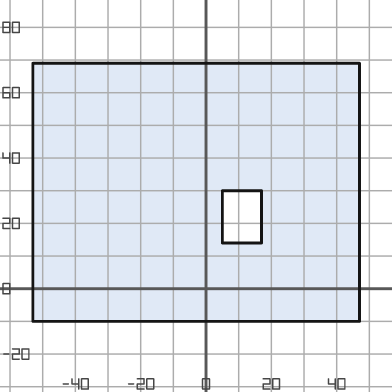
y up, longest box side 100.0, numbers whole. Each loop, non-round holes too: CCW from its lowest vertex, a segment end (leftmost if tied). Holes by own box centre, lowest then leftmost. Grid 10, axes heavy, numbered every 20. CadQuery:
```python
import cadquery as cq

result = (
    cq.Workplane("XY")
    .moveTo(-53.0, -10.0)
    .lineTo(47.0, -10.0)
    .lineTo(47.0, 69.0)
    .lineTo(-53.0, 69.0)
    .close()
    .moveTo(5.0, 14.0)
    .lineTo(17.0, 14.0)
    .lineTo(17.0, 30.0)
    .lineTo(5.0, 30.0)
    .close()
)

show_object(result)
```